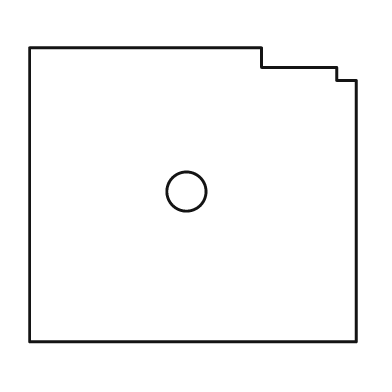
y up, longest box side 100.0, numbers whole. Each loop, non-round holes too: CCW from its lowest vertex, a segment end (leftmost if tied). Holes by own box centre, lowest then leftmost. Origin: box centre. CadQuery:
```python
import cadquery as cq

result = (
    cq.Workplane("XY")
    .moveTo(-50.0, -45.0)
    .lineTo(50.0, -45.0)
    .lineTo(50.0, 35.0)
    .lineTo(44.0, 35.0)
    .lineTo(44.0, 39.0)
    .lineTo(21.0, 39.0)
    .lineTo(21.0, 45.0)
    .lineTo(-50.0, 45.0)
    .close()
    .moveTo(-2.0, 1.0)
    .circle(6.0)
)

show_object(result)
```